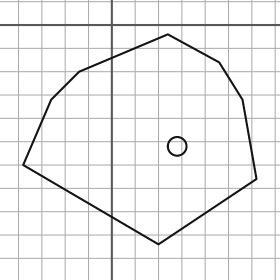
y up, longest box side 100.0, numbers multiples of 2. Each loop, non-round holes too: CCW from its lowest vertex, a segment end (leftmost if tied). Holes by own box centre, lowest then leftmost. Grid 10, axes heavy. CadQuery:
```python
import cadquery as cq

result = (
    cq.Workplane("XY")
    .moveTo(20.0, -94.0)
    .lineTo(62.0, -66.0)
    .lineTo(56.0, -32.0)
    .lineTo(46.0, -16.0)
    .lineTo(24.0, -4.0)
    .lineTo(-14.0, -20.0)
    .lineTo(-26.0, -32.0)
    .lineTo(-38.0, -60.0)
    .close()
    .moveTo(28.0, -52.0)
    .circle(4.0)
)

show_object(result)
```